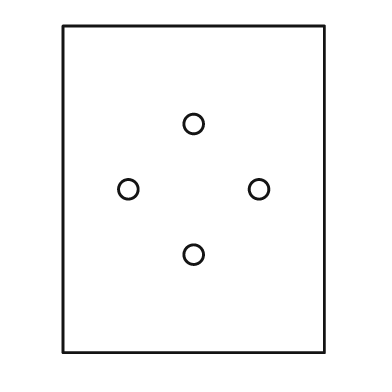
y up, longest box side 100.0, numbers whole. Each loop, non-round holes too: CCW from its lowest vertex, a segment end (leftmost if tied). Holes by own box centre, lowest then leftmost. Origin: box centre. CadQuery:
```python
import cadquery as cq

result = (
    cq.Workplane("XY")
    .moveTo(-40.0, -50.0)
    .lineTo(40.0, -50.0)
    .lineTo(40.0, 50.0)
    .lineTo(-40.0, 50.0)
    .close()
    .moveTo(0.0, -20.0)
    .circle(3.0)
    .moveTo(-20.0, 0.0)
    .circle(3.0)
    .moveTo(20.0, 0.0)
    .circle(3.0)
    .moveTo(0.0, 20.0)
    .circle(3.0)
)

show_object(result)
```